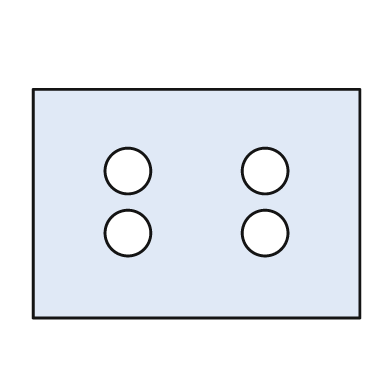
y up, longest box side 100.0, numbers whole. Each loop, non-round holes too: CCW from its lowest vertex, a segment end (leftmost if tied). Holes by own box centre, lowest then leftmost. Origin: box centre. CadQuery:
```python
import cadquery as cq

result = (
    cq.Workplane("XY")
    .moveTo(-50.0, -35.0)
    .lineTo(50.0, -35.0)
    .lineTo(50.0, 35.0)
    .lineTo(-50.0, 35.0)
    .close()
    .moveTo(-21.0, -9.0)
    .circle(7.0)
    .moveTo(21.0, -9.0)
    .circle(7.0)
    .moveTo(-21.0, 10.0)
    .circle(7.0)
    .moveTo(21.0, 10.0)
    .circle(7.0)
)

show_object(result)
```